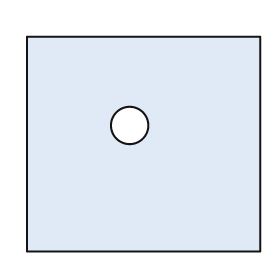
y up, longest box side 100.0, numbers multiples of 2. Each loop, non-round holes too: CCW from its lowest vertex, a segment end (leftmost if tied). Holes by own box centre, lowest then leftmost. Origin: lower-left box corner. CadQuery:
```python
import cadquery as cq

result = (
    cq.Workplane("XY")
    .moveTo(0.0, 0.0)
    .lineTo(100.0, 0.0)
    .lineTo(100.0, 92.0)
    .lineTo(0.0, 92.0)
    .close()
    .moveTo(44.0, 54.0)
    .circle(8.0)
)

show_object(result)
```